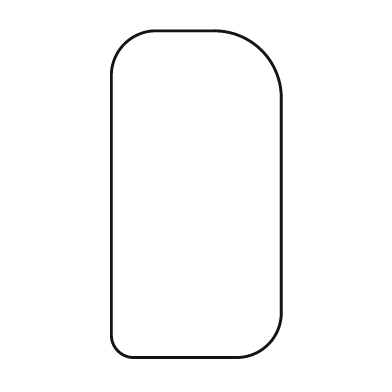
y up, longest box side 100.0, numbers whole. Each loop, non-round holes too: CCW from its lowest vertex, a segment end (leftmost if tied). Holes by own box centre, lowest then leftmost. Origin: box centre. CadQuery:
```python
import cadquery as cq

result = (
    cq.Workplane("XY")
    .moveTo(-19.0, -50.0)
    .lineTo(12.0, -50.0)
    .threePointArc((22.0, -46.0), (26.0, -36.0))
    .lineTo(26.0, 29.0)
    .threePointArc((20.0, 44.0), (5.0, 50.0))
    .lineTo(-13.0, 50.0)
    .threePointArc((-22.0, 46.0), (-26.0, 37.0))
    .lineTo(-26.0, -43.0)
    .threePointArc((-24.0, -48.0), (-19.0, -50.0))
    .close()
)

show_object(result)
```